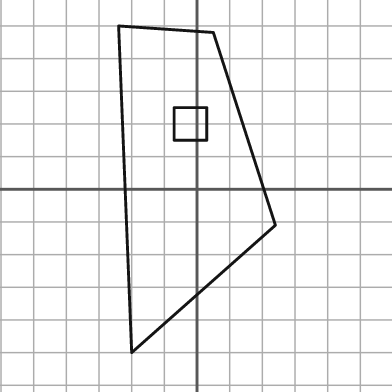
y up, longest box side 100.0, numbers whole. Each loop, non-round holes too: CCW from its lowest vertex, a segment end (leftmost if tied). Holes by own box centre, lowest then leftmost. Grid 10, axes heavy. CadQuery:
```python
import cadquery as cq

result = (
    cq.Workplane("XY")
    .moveTo(-20.0, -50.0)
    .lineTo(24.0, -11.0)
    .lineTo(5.0, 48.0)
    .lineTo(-24.0, 50.0)
    .close()
    .moveTo(-7.0, 15.0)
    .lineTo(3.0, 15.0)
    .lineTo(3.0, 25.0)
    .lineTo(-7.0, 25.0)
    .close()
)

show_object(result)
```